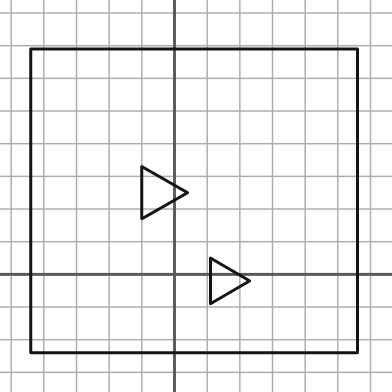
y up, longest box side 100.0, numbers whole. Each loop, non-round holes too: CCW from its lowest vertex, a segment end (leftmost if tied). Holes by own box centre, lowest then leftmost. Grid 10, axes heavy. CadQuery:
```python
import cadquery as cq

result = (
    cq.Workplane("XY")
    .moveTo(-44.0, -24.0)
    .lineTo(56.0, -24.0)
    .lineTo(56.0, 69.0)
    .lineTo(-44.0, 69.0)
    .close()
    .moveTo(11.0, -9.0)
    .lineTo(23.0, -2.0)
    .lineTo(11.0, 5.0)
    .close()
    .moveTo(-10.0, 17.0)
    .lineTo(4.0, 25.0)
    .lineTo(-10.0, 33.0)
    .close()
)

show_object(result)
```